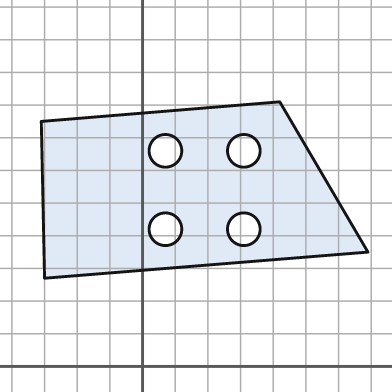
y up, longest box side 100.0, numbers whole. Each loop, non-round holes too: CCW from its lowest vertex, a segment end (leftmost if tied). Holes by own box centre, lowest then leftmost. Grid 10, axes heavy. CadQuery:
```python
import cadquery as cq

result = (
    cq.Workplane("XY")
    .moveTo(-30.0, 27.0)
    .lineTo(69.0, 35.0)
    .lineTo(42.0, 81.0)
    .lineTo(-31.0, 75.0)
    .close()
    .moveTo(7.0, 42.0)
    .circle(5.0)
    .moveTo(31.0, 42.0)
    .circle(5.0)
    .moveTo(7.0, 66.0)
    .circle(5.0)
    .moveTo(31.0, 66.0)
    .circle(5.0)
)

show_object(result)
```